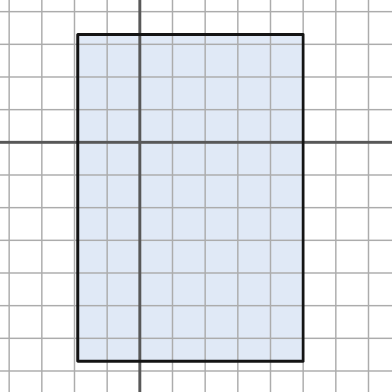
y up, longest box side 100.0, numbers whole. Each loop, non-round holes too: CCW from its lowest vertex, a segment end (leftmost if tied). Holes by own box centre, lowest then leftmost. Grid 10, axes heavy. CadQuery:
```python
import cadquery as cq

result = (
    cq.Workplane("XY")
    .moveTo(-19.0, -67.0)
    .lineTo(50.0, -67.0)
    .lineTo(50.0, 33.0)
    .lineTo(-19.0, 33.0)
    .close()
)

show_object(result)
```